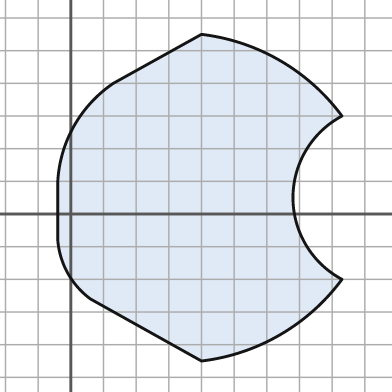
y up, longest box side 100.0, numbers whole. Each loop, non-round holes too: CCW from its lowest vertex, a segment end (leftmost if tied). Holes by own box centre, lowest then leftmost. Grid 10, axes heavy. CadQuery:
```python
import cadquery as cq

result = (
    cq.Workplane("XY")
    .moveTo(40.0, -45.0)
    .threePointArc((64.0, -37.0), (83.0, -20.0))
    .threePointArc((68.0, 5.0), (83.0, 30.0))
    .threePointArc((64.0, 47.0), (40.0, 55.0))
    .lineTo(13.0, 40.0)
    .threePointArc((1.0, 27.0), (-4.0, 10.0))
    .lineTo(-4.0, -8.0)
    .threePointArc((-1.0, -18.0), (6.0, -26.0))
    .close()
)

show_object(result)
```